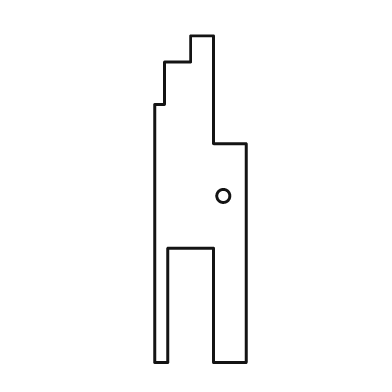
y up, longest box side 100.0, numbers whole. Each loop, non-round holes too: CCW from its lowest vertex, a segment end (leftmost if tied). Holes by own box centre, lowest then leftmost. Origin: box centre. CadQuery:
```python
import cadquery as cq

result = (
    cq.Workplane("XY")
    .moveTo(-14.0, -50.0)
    .lineTo(-10.0, -50.0)
    .lineTo(-10.0, -15.0)
    .lineTo(4.0, -15.0)
    .lineTo(4.0, -50.0)
    .lineTo(14.0, -50.0)
    .lineTo(14.0, 17.0)
    .lineTo(4.0, 17.0)
    .lineTo(4.0, 50.0)
    .lineTo(-3.0, 50.0)
    .lineTo(-3.0, 42.0)
    .lineTo(-11.0, 42.0)
    .lineTo(-11.0, 29.0)
    .lineTo(-14.0, 29.0)
    .close()
    .moveTo(7.0, 1.0)
    .circle(2.0)
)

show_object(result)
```